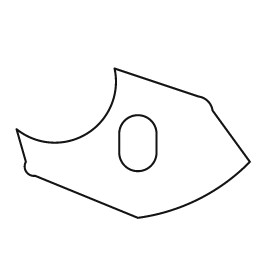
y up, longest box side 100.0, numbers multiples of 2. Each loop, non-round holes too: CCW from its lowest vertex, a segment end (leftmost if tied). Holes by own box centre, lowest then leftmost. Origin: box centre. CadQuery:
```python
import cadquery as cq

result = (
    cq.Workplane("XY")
    .moveTo(2.0, -32.0)
    .threePointArc((28.0, -24.0), (50.0, -8.0))
    .lineTo(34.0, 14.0)
    .threePointArc((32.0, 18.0), (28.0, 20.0))
    .lineTo(-8.0, 32.0)
    .threePointArc((-20.0, 4.0), (-50.0, 6.0))
    .lineTo(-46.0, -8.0)
    .threePointArc((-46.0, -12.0), (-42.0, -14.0))
    .close()
    .moveTo(-6.0, -4.0)
    .threePointArc((2.0, -12.0), (10.0, -4.0))
    .lineTo(10.0, 4.0)
    .threePointArc((2.0, 12.0), (-6.0, 4.0))
    .close()
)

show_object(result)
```